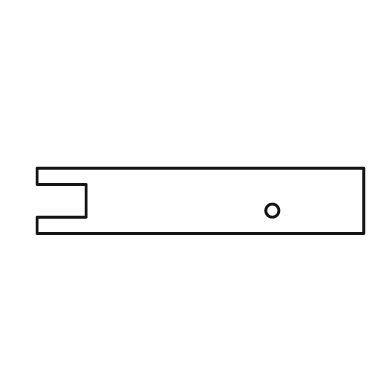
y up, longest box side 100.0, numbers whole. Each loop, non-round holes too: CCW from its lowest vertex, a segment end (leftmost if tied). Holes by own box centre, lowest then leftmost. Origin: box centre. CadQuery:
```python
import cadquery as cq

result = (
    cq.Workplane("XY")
    .moveTo(-50.0, -10.0)
    .lineTo(50.0, -10.0)
    .lineTo(50.0, 10.0)
    .lineTo(-50.0, 10.0)
    .lineTo(-50.0, 5.0)
    .lineTo(-35.0, 5.0)
    .lineTo(-35.0, -5.0)
    .lineTo(-50.0, -5.0)
    .close()
    .moveTo(22.0, -3.0)
    .circle(2.0)
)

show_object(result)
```